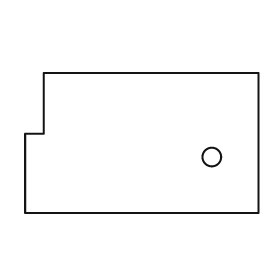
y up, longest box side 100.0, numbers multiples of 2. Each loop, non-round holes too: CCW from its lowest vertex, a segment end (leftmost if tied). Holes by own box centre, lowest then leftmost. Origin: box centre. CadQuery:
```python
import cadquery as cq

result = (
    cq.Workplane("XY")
    .moveTo(-50.0, -30.0)
    .lineTo(50.0, -30.0)
    .lineTo(50.0, 30.0)
    .lineTo(-42.0, 30.0)
    .lineTo(-42.0, 4.0)
    .lineTo(-50.0, 4.0)
    .close()
    .moveTo(30.0, -6.0)
    .circle(4.0)
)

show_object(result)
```